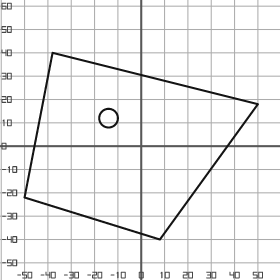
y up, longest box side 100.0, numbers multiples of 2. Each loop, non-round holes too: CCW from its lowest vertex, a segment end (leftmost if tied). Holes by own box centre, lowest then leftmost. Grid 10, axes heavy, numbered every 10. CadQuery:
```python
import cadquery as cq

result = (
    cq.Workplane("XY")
    .moveTo(8.0, -40.0)
    .lineTo(50.0, 18.0)
    .lineTo(-38.0, 40.0)
    .lineTo(-50.0, -22.0)
    .close()
    .moveTo(-14.0, 12.0)
    .circle(4.0)
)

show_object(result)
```